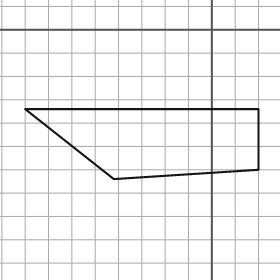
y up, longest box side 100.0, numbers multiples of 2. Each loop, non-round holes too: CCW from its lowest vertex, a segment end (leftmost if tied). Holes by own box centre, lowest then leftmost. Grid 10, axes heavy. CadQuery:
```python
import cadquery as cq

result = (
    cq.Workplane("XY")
    .moveTo(-42.0, -64.0)
    .lineTo(20.0, -60.0)
    .lineTo(20.0, -34.0)
    .lineTo(-80.0, -34.0)
    .close()
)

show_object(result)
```